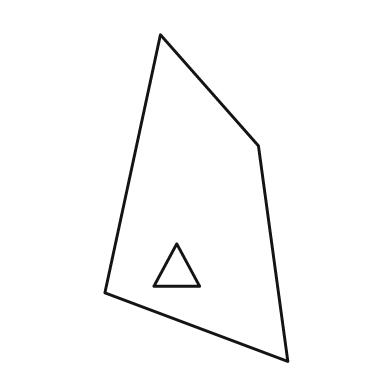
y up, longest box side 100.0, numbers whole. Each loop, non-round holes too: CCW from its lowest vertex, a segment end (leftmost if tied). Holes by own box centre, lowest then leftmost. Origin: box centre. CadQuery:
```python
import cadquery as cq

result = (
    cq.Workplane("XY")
    .moveTo(28.0, -50.0)
    .lineTo(19.0, 16.0)
    .lineTo(-11.0, 50.0)
    .lineTo(-28.0, -29.0)
    .close()
    .moveTo(-13.0, -27.0)
    .lineTo(1.0, -27.0)
    .lineTo(-6.0, -14.0)
    .close()
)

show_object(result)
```